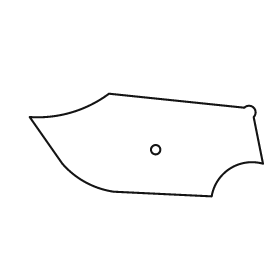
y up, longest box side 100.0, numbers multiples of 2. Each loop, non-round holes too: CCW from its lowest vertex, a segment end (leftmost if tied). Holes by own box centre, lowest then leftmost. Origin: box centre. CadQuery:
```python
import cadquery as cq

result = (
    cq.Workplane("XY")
    .moveTo(28.0, -22.0)
    .threePointArc((36.0, -10.0), (50.0, -8.0))
    .lineTo(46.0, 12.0)
    .threePointArc((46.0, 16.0), (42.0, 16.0))
    .lineTo(-16.0, 22.0)
    .threePointArc((-32.0, 14.0), (-50.0, 12.0))
    .lineTo(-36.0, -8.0)
    .threePointArc((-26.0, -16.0), (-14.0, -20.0))
    .close()
    .moveTo(4.0, -2.0)
    .circle(2.0)
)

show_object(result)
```